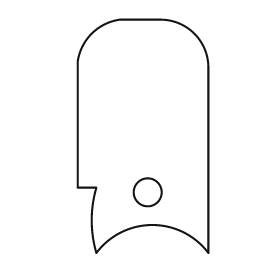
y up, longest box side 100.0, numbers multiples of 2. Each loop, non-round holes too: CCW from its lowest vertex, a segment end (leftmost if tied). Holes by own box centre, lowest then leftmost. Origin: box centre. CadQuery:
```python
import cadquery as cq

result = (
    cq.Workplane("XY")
    .moveTo(-20.0, -50.0)
    .threePointArc((4.0, -38.0), (28.0, -50.0))
    .lineTo(28.0, 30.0)
    .threePointArc((22.0, 44.0), (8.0, 50.0))
    .lineTo(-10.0, 50.0)
    .threePointArc((-22.0, 44.0), (-28.0, 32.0))
    .lineTo(-28.0, -22.0)
    .lineTo(-20.0, -22.0)
    .threePointArc((-22.0, -36.0), (-20.0, -50.0))
    .close()
    .moveTo(2.0, -24.0)
    .circle(6.0)
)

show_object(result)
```